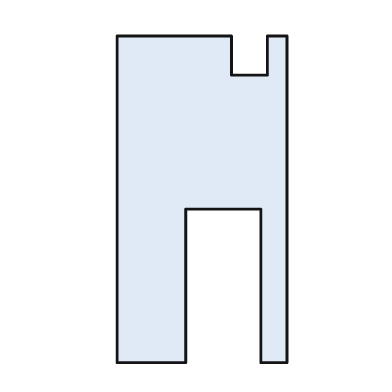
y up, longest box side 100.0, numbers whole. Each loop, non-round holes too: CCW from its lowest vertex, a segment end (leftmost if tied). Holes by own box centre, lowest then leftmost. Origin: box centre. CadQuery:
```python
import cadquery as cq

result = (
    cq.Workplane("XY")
    .moveTo(-26.0, -50.0)
    .lineTo(-5.0, -50.0)
    .lineTo(-5.0, -3.0)
    .lineTo(18.0, -3.0)
    .lineTo(18.0, -50.0)
    .lineTo(26.0, -50.0)
    .lineTo(26.0, 50.0)
    .lineTo(20.0, 50.0)
    .lineTo(20.0, 38.0)
    .lineTo(9.0, 38.0)
    .lineTo(9.0, 50.0)
    .lineTo(-26.0, 50.0)
    .close()
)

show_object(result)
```